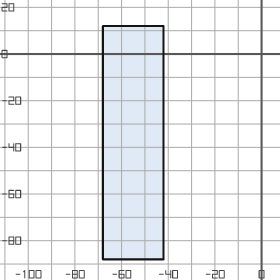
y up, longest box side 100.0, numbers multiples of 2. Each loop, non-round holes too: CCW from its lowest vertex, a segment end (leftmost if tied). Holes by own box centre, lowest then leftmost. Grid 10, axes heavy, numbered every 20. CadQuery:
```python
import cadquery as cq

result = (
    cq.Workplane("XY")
    .moveTo(-68.0, -88.0)
    .lineTo(-42.0, -88.0)
    .lineTo(-42.0, 12.0)
    .lineTo(-68.0, 12.0)
    .close()
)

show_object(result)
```